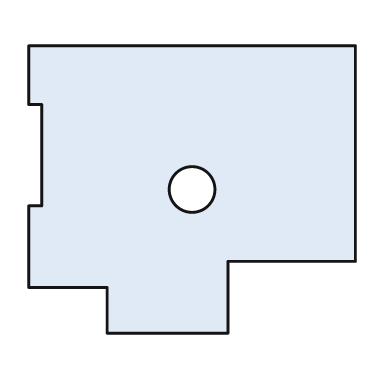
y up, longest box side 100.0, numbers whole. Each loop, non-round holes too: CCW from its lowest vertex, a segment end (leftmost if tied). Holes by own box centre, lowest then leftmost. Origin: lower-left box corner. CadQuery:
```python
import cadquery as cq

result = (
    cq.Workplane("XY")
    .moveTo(24.0, 0.0)
    .lineTo(61.0, 0.0)
    .lineTo(61.0, 22.0)
    .lineTo(100.0, 22.0)
    .lineTo(100.0, 88.0)
    .lineTo(0.0, 88.0)
    .lineTo(0.0, 70.0)
    .lineTo(4.0, 70.0)
    .lineTo(4.0, 39.0)
    .lineTo(0.0, 39.0)
    .lineTo(0.0, 14.0)
    .lineTo(24.0, 14.0)
    .close()
    .moveTo(50.0, 44.0)
    .circle(7.0)
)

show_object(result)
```